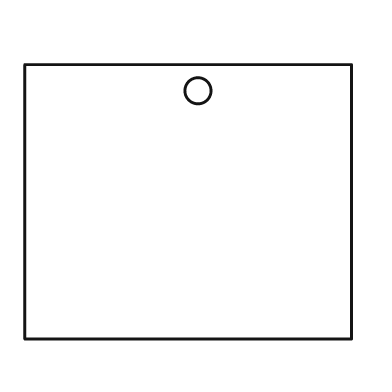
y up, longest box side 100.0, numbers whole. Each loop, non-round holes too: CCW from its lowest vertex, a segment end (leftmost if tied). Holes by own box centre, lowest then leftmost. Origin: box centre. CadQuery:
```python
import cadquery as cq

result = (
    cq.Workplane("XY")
    .moveTo(-50.0, -42.0)
    .lineTo(50.0, -42.0)
    .lineTo(50.0, 42.0)
    .lineTo(-50.0, 42.0)
    .close()
    .moveTo(3.0, 34.0)
    .circle(4.0)
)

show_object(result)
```